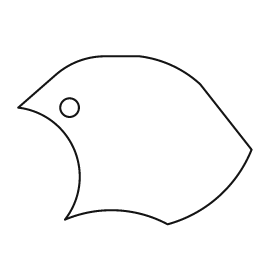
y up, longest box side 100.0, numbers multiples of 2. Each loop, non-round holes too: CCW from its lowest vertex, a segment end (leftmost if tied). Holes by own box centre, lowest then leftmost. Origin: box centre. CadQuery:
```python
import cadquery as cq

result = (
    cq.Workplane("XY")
    .moveTo(14.0, -36.0)
    .threePointArc((36.0, -24.0), (50.0, -4.0))
    .lineTo(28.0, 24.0)
    .threePointArc((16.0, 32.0), (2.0, 36.0))
    .lineTo(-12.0, 36.0)
    .threePointArc((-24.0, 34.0), (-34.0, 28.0))
    .lineTo(-50.0, 14.0)
    .threePointArc((-26.0, -4.0), (-30.0, -34.0))
    .threePointArc((-8.0, -30.0), (14.0, -36.0))
    .close()
    .moveTo(-28.0, 14.0)
    .circle(4.0)
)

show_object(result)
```